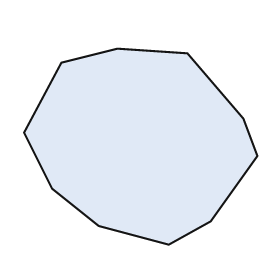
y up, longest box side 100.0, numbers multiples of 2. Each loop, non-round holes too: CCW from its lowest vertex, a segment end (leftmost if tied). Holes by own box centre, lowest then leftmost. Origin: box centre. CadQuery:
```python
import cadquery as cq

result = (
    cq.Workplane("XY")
    .moveTo(12.0, -42.0)
    .lineTo(30.0, -32.0)
    .lineTo(50.0, -4.0)
    .lineTo(44.0, 12.0)
    .lineTo(20.0, 40.0)
    .lineTo(-10.0, 42.0)
    .lineTo(-34.0, 36.0)
    .lineTo(-50.0, 6.0)
    .lineTo(-38.0, -18.0)
    .lineTo(-18.0, -34.0)
    .close()
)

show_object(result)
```